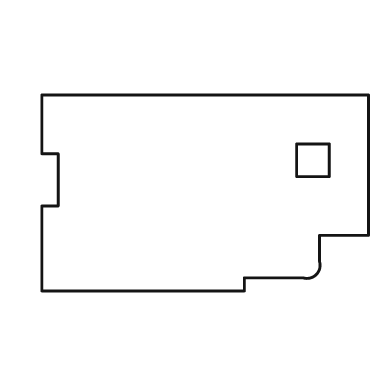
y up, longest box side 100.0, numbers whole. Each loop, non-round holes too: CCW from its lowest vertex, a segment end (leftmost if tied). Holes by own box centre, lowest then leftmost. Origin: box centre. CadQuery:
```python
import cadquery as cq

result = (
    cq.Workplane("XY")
    .moveTo(-50.0, -30.0)
    .lineTo(12.0, -30.0)
    .lineTo(12.0, -26.0)
    .lineTo(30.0, -26.0)
    .threePointArc((34.0, -25.0), (35.0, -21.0))
    .lineTo(35.0, -13.0)
    .lineTo(50.0, -13.0)
    .lineTo(50.0, 30.0)
    .lineTo(-50.0, 30.0)
    .lineTo(-50.0, 12.0)
    .lineTo(-45.0, 12.0)
    .lineTo(-45.0, -4.0)
    .lineTo(-50.0, -4.0)
    .close()
    .moveTo(28.0, 5.0)
    .lineTo(38.0, 5.0)
    .lineTo(38.0, 15.0)
    .lineTo(28.0, 15.0)
    .close()
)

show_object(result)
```